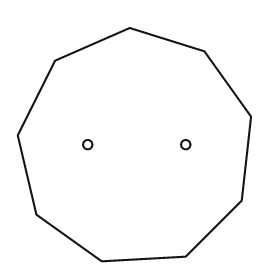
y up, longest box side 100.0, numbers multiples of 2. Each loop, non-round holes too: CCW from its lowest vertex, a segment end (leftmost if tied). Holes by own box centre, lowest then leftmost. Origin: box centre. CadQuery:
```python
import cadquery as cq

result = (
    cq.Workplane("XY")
    .moveTo(-14.0, -50.0)
    .lineTo(22.0, -48.0)
    .lineTo(46.0, -24.0)
    .lineTo(50.0, 12.0)
    .lineTo(30.0, 40.0)
    .lineTo(-2.0, 50.0)
    .lineTo(-34.0, 36.0)
    .lineTo(-50.0, 4.0)
    .lineTo(-42.0, -30.0)
    .close()
    .moveTo(-20.0, 0.0)
    .circle(2.0)
    .moveTo(22.0, 0.0)
    .circle(2.0)
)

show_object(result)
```